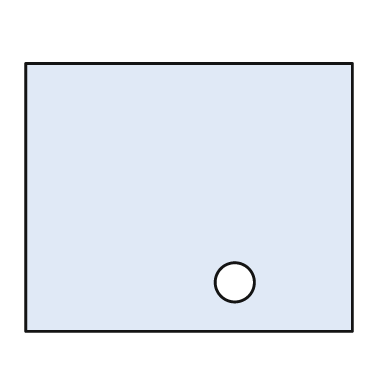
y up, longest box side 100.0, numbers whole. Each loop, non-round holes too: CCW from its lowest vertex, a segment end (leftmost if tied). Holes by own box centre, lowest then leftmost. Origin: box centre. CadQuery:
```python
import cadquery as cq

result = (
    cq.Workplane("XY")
    .moveTo(-50.0, -41.0)
    .lineTo(50.0, -41.0)
    .lineTo(50.0, 41.0)
    .lineTo(-50.0, 41.0)
    .close()
    .moveTo(14.0, -26.0)
    .circle(6.0)
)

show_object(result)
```